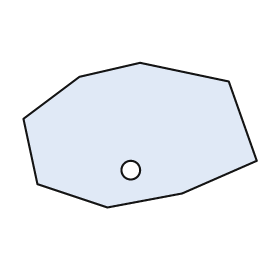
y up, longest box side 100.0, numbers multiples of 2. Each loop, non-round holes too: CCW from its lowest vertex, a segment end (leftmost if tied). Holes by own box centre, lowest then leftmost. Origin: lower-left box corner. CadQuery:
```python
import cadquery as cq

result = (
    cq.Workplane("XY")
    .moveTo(36.0, 0.0)
    .lineTo(68.0, 6.0)
    .lineTo(100.0, 20.0)
    .lineTo(88.0, 54.0)
    .lineTo(50.0, 62.0)
    .lineTo(24.0, 56.0)
    .lineTo(0.0, 38.0)
    .lineTo(6.0, 10.0)
    .close()
    .moveTo(46.0, 16.0)
    .circle(4.0)
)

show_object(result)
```